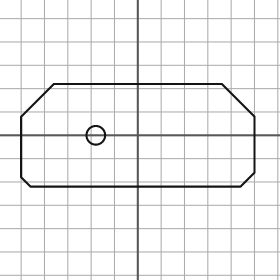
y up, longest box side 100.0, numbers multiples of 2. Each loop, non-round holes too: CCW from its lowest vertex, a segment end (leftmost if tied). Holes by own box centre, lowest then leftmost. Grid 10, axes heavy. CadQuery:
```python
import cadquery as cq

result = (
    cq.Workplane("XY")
    .moveTo(-46.0, -22.0)
    .lineTo(44.0, -22.0)
    .lineTo(50.0, -16.0)
    .lineTo(50.0, 8.0)
    .lineTo(36.0, 22.0)
    .lineTo(-36.0, 22.0)
    .lineTo(-50.0, 8.0)
    .lineTo(-50.0, -18.0)
    .close()
    .moveTo(-18.0, 0.0)
    .circle(4.0)
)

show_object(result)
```